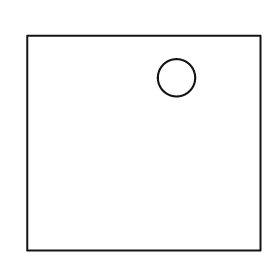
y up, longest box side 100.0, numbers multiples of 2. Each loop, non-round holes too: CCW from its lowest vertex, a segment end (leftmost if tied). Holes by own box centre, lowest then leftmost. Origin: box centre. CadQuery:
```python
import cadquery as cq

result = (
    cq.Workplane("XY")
    .moveTo(-50.0, -46.0)
    .lineTo(50.0, -46.0)
    .lineTo(50.0, 46.0)
    .lineTo(-50.0, 46.0)
    .close()
    .moveTo(14.0, 28.0)
    .circle(8.0)
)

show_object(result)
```